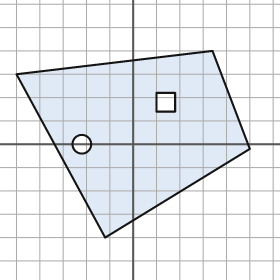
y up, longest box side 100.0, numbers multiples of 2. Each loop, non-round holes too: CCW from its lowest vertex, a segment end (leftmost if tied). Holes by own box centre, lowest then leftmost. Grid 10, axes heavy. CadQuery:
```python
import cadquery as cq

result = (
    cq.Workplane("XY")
    .moveTo(-12.0, -40.0)
    .lineTo(50.0, -2.0)
    .lineTo(34.0, 40.0)
    .lineTo(-50.0, 30.0)
    .close()
    .moveTo(-22.0, 0.0)
    .circle(4.0)
    .moveTo(10.0, 14.0)
    .lineTo(18.0, 14.0)
    .lineTo(18.0, 22.0)
    .lineTo(10.0, 22.0)
    .close()
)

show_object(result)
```